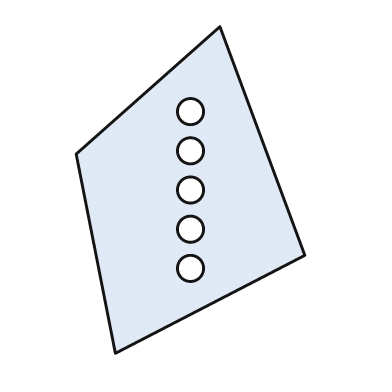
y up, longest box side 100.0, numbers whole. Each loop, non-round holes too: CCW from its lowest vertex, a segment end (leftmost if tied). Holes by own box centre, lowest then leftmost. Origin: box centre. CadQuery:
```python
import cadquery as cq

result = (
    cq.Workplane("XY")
    .moveTo(-23.0, -50.0)
    .lineTo(35.0, -20.0)
    .lineTo(9.0, 50.0)
    .lineTo(-35.0, 11.0)
    .close()
    .moveTo(0.0, -24.0)
    .circle(4.0)
    .moveTo(0.0, -12.0)
    .circle(4.0)
    .moveTo(0.0, 0.0)
    .circle(4.0)
    .moveTo(0.0, 12.0)
    .circle(4.0)
    .moveTo(0.0, 24.0)
    .circle(4.0)
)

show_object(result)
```